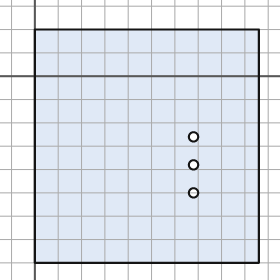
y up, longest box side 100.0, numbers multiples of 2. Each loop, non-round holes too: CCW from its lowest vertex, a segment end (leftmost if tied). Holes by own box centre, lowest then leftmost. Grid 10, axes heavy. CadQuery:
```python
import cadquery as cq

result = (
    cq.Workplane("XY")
    .moveTo(0.0, -80.0)
    .lineTo(96.0, -80.0)
    .lineTo(96.0, 20.0)
    .lineTo(0.0, 20.0)
    .close()
    .moveTo(68.0, -50.0)
    .circle(2.0)
    .moveTo(68.0, -38.0)
    .circle(2.0)
    .moveTo(68.0, -26.0)
    .circle(2.0)
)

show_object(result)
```